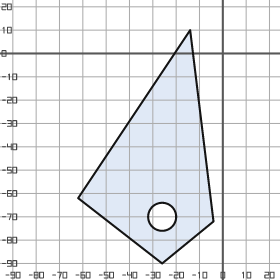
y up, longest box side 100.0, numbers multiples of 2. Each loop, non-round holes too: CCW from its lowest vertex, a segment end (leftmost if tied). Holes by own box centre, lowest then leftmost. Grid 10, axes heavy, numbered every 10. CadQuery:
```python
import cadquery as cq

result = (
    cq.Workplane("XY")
    .moveTo(-26.0, -90.0)
    .lineTo(-4.0, -72.0)
    .lineTo(-14.0, 10.0)
    .lineTo(-62.0, -62.0)
    .close()
    .moveTo(-26.0, -70.0)
    .circle(6.0)
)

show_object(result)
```